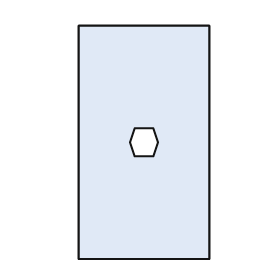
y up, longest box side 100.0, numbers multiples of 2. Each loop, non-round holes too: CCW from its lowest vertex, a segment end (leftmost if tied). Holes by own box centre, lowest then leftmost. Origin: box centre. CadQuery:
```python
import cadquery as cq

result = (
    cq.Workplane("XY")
    .moveTo(-28.0, -50.0)
    .lineTo(28.0, -50.0)
    .lineTo(28.0, 50.0)
    .lineTo(-28.0, 50.0)
    .close()
    .moveTo(-4.0, -6.0)
    .lineTo(4.0, -6.0)
    .lineTo(6.0, 0.0)
    .lineTo(4.0, 6.0)
    .lineTo(-4.0, 6.0)
    .lineTo(-6.0, 0.0)
    .close()
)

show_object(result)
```